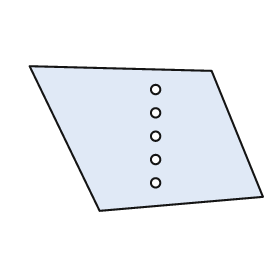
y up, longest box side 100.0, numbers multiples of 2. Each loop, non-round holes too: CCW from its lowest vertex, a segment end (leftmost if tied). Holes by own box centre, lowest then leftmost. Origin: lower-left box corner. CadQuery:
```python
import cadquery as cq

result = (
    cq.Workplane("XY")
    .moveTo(30.0, 0.0)
    .lineTo(100.0, 6.0)
    .lineTo(78.0, 60.0)
    .lineTo(0.0, 62.0)
    .close()
    .moveTo(54.0, 12.0)
    .circle(2.0)
    .moveTo(54.0, 22.0)
    .circle(2.0)
    .moveTo(54.0, 32.0)
    .circle(2.0)
    .moveTo(54.0, 42.0)
    .circle(2.0)
    .moveTo(54.0, 52.0)
    .circle(2.0)
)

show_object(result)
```